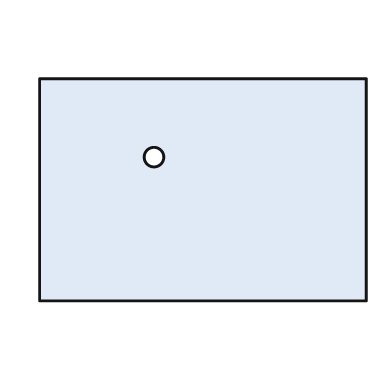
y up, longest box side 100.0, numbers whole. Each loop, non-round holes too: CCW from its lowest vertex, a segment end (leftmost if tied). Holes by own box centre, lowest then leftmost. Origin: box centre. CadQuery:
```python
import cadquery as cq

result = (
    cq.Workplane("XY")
    .moveTo(-50.0, -34.0)
    .lineTo(50.0, -34.0)
    .lineTo(50.0, 34.0)
    .lineTo(-50.0, 34.0)
    .close()
    .moveTo(-15.0, 10.0)
    .circle(3.0)
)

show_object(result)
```